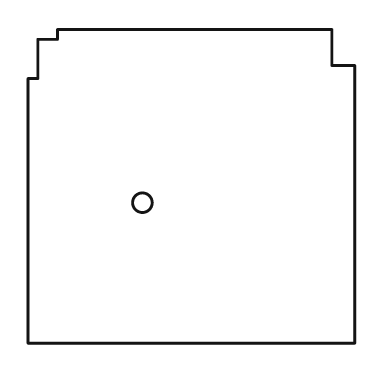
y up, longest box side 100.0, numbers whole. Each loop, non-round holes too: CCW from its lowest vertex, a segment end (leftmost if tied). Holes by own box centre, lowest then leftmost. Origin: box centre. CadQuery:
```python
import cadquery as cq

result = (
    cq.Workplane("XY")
    .moveTo(-50.0, -48.0)
    .lineTo(50.0, -48.0)
    .lineTo(50.0, 37.0)
    .lineTo(43.0, 37.0)
    .lineTo(43.0, 48.0)
    .lineTo(-41.0, 48.0)
    .lineTo(-41.0, 45.0)
    .lineTo(-47.0, 45.0)
    .lineTo(-47.0, 33.0)
    .lineTo(-50.0, 33.0)
    .close()
    .moveTo(-15.0, -5.0)
    .circle(3.0)
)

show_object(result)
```